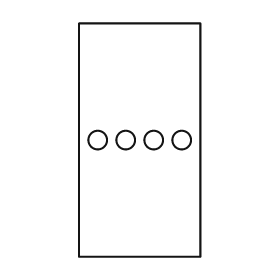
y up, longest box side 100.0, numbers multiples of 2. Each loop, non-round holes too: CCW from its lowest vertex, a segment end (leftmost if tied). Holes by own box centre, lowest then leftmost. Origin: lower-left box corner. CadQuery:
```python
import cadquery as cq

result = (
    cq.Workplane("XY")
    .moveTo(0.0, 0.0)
    .lineTo(52.0, 0.0)
    .lineTo(52.0, 100.0)
    .lineTo(0.0, 100.0)
    .close()
    .moveTo(8.0, 50.0)
    .circle(4.0)
    .moveTo(20.0, 50.0)
    .circle(4.0)
    .moveTo(32.0, 50.0)
    .circle(4.0)
    .moveTo(44.0, 50.0)
    .circle(4.0)
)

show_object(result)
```